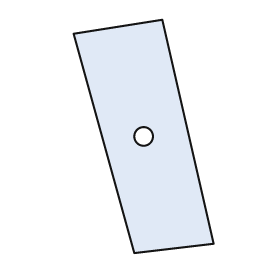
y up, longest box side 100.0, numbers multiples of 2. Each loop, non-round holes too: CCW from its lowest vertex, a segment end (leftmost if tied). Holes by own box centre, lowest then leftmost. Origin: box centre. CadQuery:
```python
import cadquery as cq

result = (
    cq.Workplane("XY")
    .moveTo(-4.0, -50.0)
    .lineTo(30.0, -46.0)
    .lineTo(8.0, 50.0)
    .lineTo(-30.0, 44.0)
    .close()
    .moveTo(0.0, 0.0)
    .circle(4.0)
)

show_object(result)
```